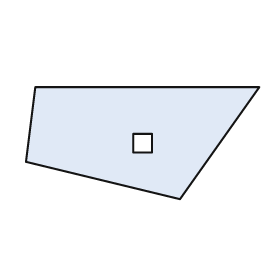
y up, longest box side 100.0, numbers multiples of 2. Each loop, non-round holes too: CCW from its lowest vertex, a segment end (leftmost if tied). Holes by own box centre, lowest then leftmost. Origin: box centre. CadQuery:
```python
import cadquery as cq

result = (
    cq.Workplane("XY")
    .moveTo(16.0, -24.0)
    .lineTo(50.0, 24.0)
    .lineTo(-46.0, 24.0)
    .lineTo(-50.0, -8.0)
    .close()
    .moveTo(-4.0, -4.0)
    .lineTo(4.0, -4.0)
    .lineTo(4.0, 4.0)
    .lineTo(-4.0, 4.0)
    .close()
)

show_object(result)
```